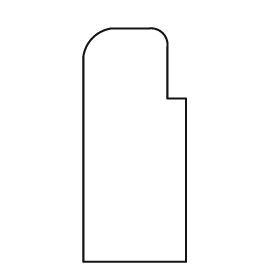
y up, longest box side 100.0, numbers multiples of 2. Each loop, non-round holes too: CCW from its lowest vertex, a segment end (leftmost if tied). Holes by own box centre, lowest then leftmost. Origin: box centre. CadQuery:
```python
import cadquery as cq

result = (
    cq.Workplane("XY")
    .moveTo(-22.0, -50.0)
    .lineTo(22.0, -50.0)
    .lineTo(22.0, 20.0)
    .lineTo(14.0, 20.0)
    .lineTo(14.0, 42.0)
    .threePointArc((12.0, 48.0), (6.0, 50.0))
    .lineTo(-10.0, 50.0)
    .threePointArc((-18.0, 46.0), (-22.0, 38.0))
    .close()
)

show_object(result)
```